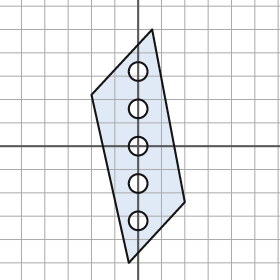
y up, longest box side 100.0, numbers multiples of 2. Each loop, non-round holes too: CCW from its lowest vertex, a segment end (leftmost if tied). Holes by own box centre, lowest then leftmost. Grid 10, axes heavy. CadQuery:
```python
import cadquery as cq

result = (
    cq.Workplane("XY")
    .moveTo(-4.0, -50.0)
    .lineTo(20.0, -24.0)
    .lineTo(6.0, 50.0)
    .lineTo(-20.0, 22.0)
    .close()
    .moveTo(0.0, -32.0)
    .circle(4.0)
    .moveTo(0.0, -16.0)
    .circle(4.0)
    .moveTo(0.0, 0.0)
    .circle(4.0)
    .moveTo(0.0, 16.0)
    .circle(4.0)
    .moveTo(0.0, 32.0)
    .circle(4.0)
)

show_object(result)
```